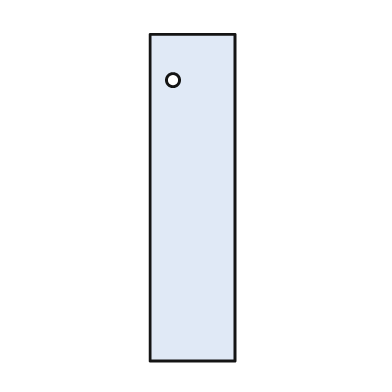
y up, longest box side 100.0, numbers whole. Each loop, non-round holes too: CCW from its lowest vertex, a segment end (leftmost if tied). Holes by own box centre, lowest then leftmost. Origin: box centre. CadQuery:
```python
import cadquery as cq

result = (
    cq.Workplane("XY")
    .moveTo(-13.0, -50.0)
    .lineTo(13.0, -50.0)
    .lineTo(13.0, 50.0)
    .lineTo(-13.0, 50.0)
    .close()
    .moveTo(-6.0, 36.0)
    .circle(2.0)
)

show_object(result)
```